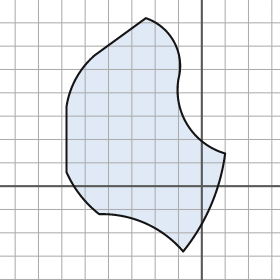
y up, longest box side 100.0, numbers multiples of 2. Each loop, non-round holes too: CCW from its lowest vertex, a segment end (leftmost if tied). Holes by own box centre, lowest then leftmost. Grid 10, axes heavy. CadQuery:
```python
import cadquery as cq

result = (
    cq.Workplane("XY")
    .moveTo(-8.0, -28.0)
    .threePointArc((4.0, -8.0), (10.0, 14.0))
    .threePointArc((-6.0, 26.0), (-10.0, 46.0))
    .threePointArc((-12.0, 62.0), (-24.0, 72.0))
    .lineTo(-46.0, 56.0)
    .threePointArc((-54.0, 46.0), (-58.0, 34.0))
    .lineTo(-58.0, 6.0)
    .threePointArc((-52.0, -4.0), (-44.0, -12.0))
    .threePointArc((-24.0, -16.0), (-8.0, -28.0))
    .close()
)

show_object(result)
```